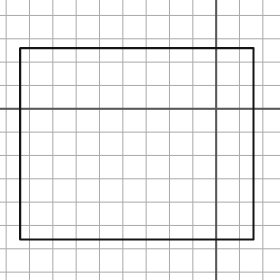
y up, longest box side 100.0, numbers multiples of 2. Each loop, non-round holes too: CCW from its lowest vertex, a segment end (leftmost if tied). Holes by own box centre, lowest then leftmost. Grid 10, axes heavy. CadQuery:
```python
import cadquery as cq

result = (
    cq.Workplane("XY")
    .moveTo(-84.0, -56.0)
    .lineTo(16.0, -56.0)
    .lineTo(16.0, 26.0)
    .lineTo(-84.0, 26.0)
    .close()
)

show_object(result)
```